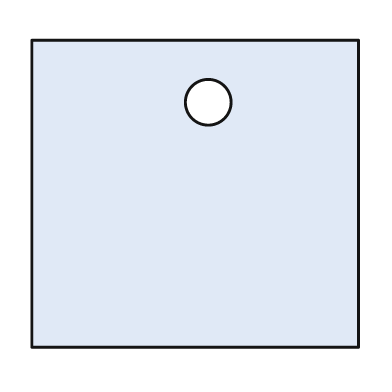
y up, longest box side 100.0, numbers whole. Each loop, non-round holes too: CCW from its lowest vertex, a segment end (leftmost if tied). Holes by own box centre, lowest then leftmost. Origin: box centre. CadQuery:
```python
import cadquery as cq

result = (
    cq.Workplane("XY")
    .moveTo(-50.0, -47.0)
    .lineTo(50.0, -47.0)
    .lineTo(50.0, 47.0)
    .lineTo(-50.0, 47.0)
    .close()
    .moveTo(4.0, 28.0)
    .circle(7.0)
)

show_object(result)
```